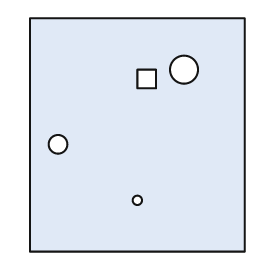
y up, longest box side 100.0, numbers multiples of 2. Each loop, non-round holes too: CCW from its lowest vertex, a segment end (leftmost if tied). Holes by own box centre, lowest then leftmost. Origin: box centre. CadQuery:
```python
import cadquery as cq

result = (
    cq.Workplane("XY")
    .moveTo(-46.0, -50.0)
    .lineTo(46.0, -50.0)
    .lineTo(46.0, 50.0)
    .lineTo(-46.0, 50.0)
    .close()
    .moveTo(0.0, -28.0)
    .circle(2.0)
    .moveTo(-34.0, -4.0)
    .circle(4.0)
    .moveTo(0.0, 20.0)
    .lineTo(8.0, 20.0)
    .lineTo(8.0, 28.0)
    .lineTo(0.0, 28.0)
    .close()
    .moveTo(20.0, 28.0)
    .circle(6.0)
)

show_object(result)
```